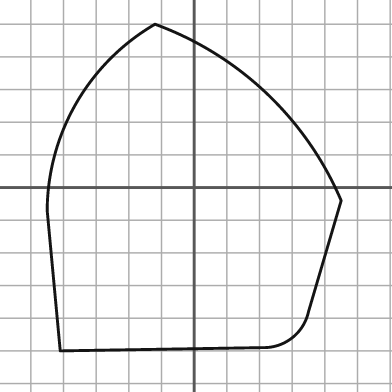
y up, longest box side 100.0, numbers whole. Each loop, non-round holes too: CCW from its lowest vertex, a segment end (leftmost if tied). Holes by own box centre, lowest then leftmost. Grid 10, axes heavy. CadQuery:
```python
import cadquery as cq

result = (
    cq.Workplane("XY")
    .moveTo(-41.0, -50.0)
    .lineTo(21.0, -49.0)
    .threePointArc((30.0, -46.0), (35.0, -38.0))
    .lineTo(45.0, -4.0)
    .threePointArc((22.0, 29.0), (-12.0, 50.0))
    .threePointArc((-36.0, 26.0), (-45.0, -7.0))
    .close()
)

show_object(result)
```